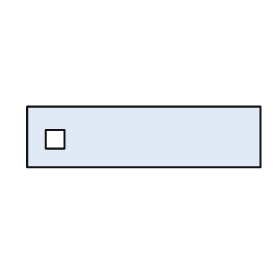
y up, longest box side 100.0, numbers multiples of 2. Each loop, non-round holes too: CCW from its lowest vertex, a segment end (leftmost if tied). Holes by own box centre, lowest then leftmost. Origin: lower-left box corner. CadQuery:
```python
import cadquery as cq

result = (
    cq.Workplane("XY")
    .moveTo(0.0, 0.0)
    .lineTo(100.0, 0.0)
    .lineTo(100.0, 26.0)
    .lineTo(0.0, 26.0)
    .close()
    .moveTo(8.0, 8.0)
    .lineTo(16.0, 8.0)
    .lineTo(16.0, 16.0)
    .lineTo(8.0, 16.0)
    .close()
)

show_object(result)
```